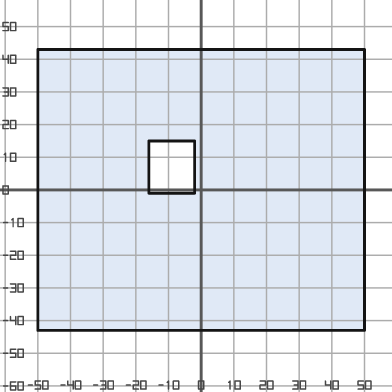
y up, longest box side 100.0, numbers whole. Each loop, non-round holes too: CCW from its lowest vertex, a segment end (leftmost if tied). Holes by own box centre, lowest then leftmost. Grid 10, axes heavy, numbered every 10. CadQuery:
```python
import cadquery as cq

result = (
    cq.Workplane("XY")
    .moveTo(-50.0, -43.0)
    .lineTo(50.0, -43.0)
    .lineTo(50.0, 43.0)
    .lineTo(-50.0, 43.0)
    .close()
    .moveTo(-16.0, -1.0)
    .lineTo(-2.0, -1.0)
    .lineTo(-2.0, 15.0)
    .lineTo(-16.0, 15.0)
    .close()
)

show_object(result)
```